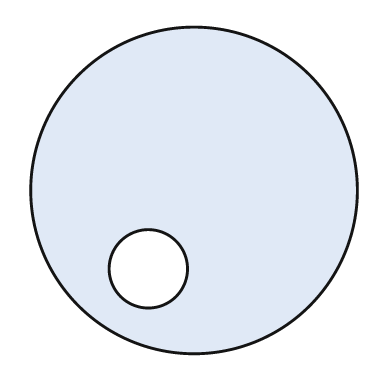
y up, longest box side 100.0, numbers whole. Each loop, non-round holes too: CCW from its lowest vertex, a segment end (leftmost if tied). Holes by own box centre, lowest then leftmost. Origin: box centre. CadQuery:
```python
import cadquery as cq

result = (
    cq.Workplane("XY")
    .moveTo(0.0, 0.0)
    .circle(50.0)
    .moveTo(-14.0, -24.0)
    .circle(12.0)
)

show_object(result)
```